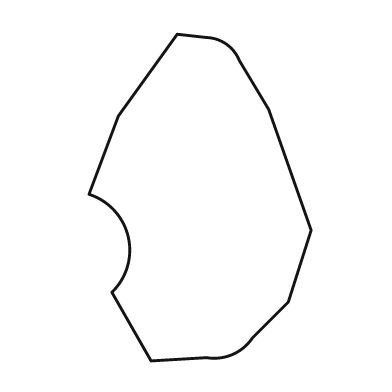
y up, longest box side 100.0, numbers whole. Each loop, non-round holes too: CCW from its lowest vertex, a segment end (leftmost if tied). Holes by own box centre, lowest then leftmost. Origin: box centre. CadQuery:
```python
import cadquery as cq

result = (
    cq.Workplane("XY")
    .moveTo(-15.0, -50.0)
    .lineTo(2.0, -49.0)
    .threePointArc((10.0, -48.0), (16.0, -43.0))
    .lineTo(27.0, -32.0)
    .lineTo(34.0, -10.0)
    .lineTo(21.0, 27.0)
    .lineTo(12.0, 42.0)
    .threePointArc((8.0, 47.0), (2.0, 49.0))
    .lineTo(-7.0, 50.0)
    .lineTo(-25.0, 25.0)
    .lineTo(-34.0, 1.0)
    .threePointArc((-22.0, -12.0), (-27.0, -29.0))
    .close()
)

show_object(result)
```